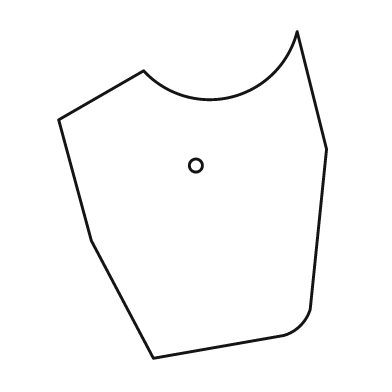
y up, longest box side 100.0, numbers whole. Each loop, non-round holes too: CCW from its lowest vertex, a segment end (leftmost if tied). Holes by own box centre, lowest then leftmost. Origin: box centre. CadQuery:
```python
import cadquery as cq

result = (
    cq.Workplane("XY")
    .moveTo(-12.0, -50.0)
    .lineTo(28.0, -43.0)
    .threePointArc((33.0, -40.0), (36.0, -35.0))
    .lineTo(41.0, 14.0)
    .lineTo(32.0, 50.0)
    .threePointArc((12.0, 30.0), (-15.0, 38.0))
    .lineTo(-41.0, 23.0)
    .lineTo(-31.0, -14.0)
    .close()
    .moveTo(1.0, 9.0)
    .circle(2.0)
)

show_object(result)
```